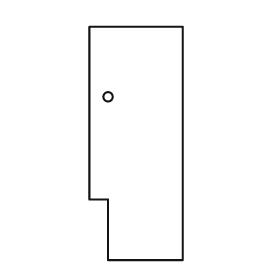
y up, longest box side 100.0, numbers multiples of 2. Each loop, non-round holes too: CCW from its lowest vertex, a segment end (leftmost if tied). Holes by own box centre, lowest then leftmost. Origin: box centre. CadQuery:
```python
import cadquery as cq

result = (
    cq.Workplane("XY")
    .moveTo(-12.0, -50.0)
    .lineTo(20.0, -50.0)
    .lineTo(20.0, 50.0)
    .lineTo(-20.0, 50.0)
    .lineTo(-20.0, -24.0)
    .lineTo(-12.0, -24.0)
    .close()
    .moveTo(-12.0, 20.0)
    .circle(2.0)
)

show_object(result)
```